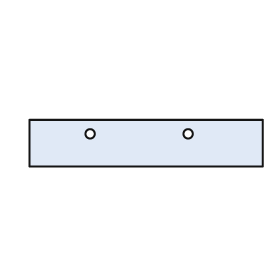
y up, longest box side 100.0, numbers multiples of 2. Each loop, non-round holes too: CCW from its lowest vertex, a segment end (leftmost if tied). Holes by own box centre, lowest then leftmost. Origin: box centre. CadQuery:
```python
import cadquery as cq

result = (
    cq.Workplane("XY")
    .moveTo(-50.0, -10.0)
    .lineTo(50.0, -10.0)
    .lineTo(50.0, 10.0)
    .lineTo(-50.0, 10.0)
    .close()
    .moveTo(-24.0, 4.0)
    .circle(2.0)
    .moveTo(18.0, 4.0)
    .circle(2.0)
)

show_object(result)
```